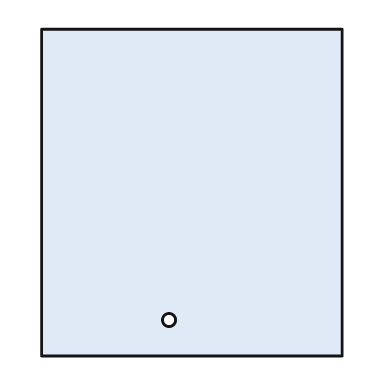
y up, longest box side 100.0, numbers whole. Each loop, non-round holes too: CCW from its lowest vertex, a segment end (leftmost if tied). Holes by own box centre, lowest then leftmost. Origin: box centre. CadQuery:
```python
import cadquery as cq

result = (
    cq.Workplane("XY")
    .moveTo(-46.0, -50.0)
    .lineTo(46.0, -50.0)
    .lineTo(46.0, 50.0)
    .lineTo(-46.0, 50.0)
    .close()
    .moveTo(-7.0, -39.0)
    .circle(2.0)
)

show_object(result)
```